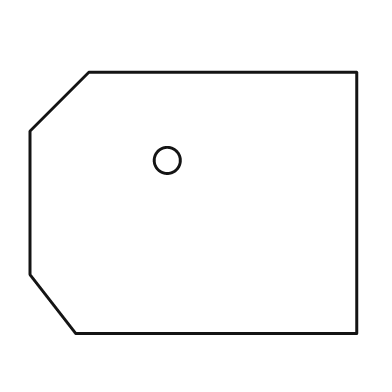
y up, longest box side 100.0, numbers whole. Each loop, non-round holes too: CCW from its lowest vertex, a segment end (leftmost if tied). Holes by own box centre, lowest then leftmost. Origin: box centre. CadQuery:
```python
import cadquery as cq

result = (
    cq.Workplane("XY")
    .moveTo(-36.0, -40.0)
    .lineTo(50.0, -40.0)
    .lineTo(50.0, 40.0)
    .lineTo(-32.0, 40.0)
    .lineTo(-50.0, 22.0)
    .lineTo(-50.0, -22.0)
    .close()
    .moveTo(-8.0, 13.0)
    .circle(4.0)
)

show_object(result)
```